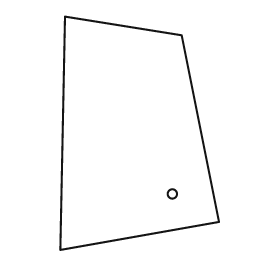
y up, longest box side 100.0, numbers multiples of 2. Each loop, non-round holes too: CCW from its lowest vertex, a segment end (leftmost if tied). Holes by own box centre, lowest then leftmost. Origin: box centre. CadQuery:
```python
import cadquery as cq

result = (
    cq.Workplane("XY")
    .moveTo(-34.0, -50.0)
    .lineTo(34.0, -38.0)
    .lineTo(18.0, 42.0)
    .lineTo(-32.0, 50.0)
    .close()
    .moveTo(14.0, -26.0)
    .circle(2.0)
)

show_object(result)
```